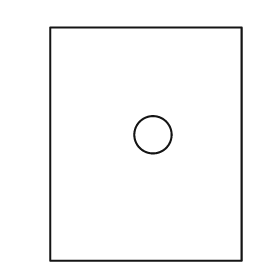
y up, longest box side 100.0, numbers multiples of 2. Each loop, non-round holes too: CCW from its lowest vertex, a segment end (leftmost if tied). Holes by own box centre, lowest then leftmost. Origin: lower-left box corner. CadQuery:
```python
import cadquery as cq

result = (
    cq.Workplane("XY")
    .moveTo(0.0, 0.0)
    .lineTo(82.0, 0.0)
    .lineTo(82.0, 100.0)
    .lineTo(0.0, 100.0)
    .close()
    .moveTo(44.0, 54.0)
    .circle(8.0)
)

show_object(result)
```